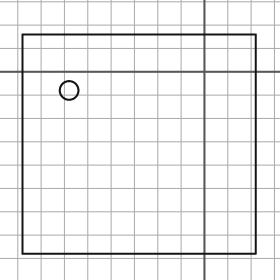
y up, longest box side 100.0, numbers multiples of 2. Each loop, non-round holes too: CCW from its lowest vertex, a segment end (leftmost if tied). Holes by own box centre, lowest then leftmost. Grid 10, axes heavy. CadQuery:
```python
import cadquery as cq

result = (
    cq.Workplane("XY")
    .moveTo(-78.0, -78.0)
    .lineTo(22.0, -78.0)
    .lineTo(22.0, 16.0)
    .lineTo(-78.0, 16.0)
    .close()
    .moveTo(-58.0, -8.0)
    .circle(4.0)
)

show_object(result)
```